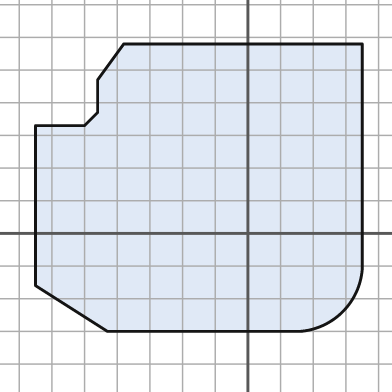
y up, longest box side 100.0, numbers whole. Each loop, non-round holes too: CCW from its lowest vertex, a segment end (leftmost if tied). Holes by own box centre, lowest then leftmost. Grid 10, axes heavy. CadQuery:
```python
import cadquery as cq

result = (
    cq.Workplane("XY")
    .moveTo(-43.0, -30.0)
    .lineTo(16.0, -30.0)
    .threePointArc((29.0, -24.0), (35.0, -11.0))
    .lineTo(35.0, 58.0)
    .lineTo(-38.0, 58.0)
    .lineTo(-46.0, 47.0)
    .lineTo(-46.0, 37.0)
    .lineTo(-50.0, 33.0)
    .lineTo(-65.0, 33.0)
    .lineTo(-65.0, -16.0)
    .close()
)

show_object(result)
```